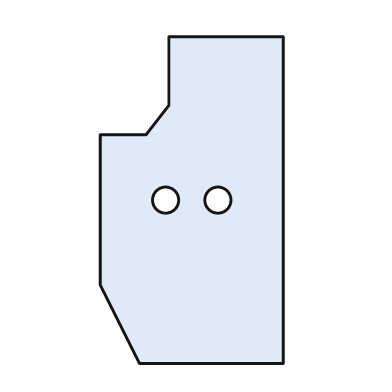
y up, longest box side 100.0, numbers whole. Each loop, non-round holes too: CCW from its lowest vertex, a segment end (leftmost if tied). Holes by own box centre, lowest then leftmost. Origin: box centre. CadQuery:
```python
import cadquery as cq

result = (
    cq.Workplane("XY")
    .moveTo(-16.0, -50.0)
    .lineTo(28.0, -50.0)
    .lineTo(28.0, 50.0)
    .lineTo(-7.0, 50.0)
    .lineTo(-7.0, 29.0)
    .lineTo(-14.0, 20.0)
    .lineTo(-28.0, 20.0)
    .lineTo(-28.0, -26.0)
    .close()
    .moveTo(-8.0, 0.0)
    .circle(4.0)
    .moveTo(8.0, 0.0)
    .circle(4.0)
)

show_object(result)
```